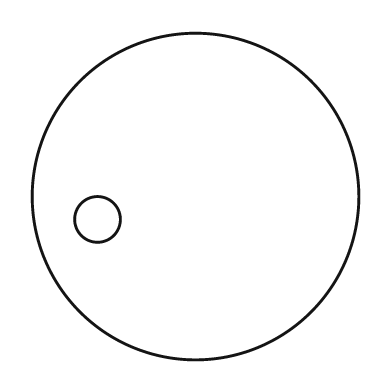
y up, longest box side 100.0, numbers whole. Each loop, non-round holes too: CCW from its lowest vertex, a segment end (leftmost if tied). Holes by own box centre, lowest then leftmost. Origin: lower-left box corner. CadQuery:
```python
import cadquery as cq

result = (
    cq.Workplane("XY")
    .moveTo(50.0, 50.0)
    .circle(50.0)
    .moveTo(20.0, 43.0)
    .circle(7.0)
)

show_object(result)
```